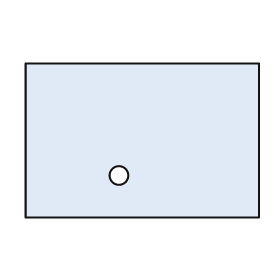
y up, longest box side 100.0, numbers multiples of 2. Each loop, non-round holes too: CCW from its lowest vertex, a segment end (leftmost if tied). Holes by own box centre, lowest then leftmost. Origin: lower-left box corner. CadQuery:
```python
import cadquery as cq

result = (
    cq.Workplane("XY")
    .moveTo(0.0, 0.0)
    .lineTo(100.0, 0.0)
    .lineTo(100.0, 66.0)
    .lineTo(0.0, 66.0)
    .close()
    .moveTo(40.0, 18.0)
    .circle(4.0)
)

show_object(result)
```